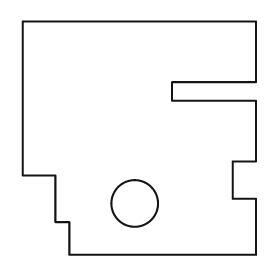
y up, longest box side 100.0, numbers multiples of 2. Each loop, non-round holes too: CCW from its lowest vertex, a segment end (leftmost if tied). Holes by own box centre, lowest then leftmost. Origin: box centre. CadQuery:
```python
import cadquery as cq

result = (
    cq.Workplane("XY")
    .moveTo(-30.0, -50.0)
    .lineTo(50.0, -50.0)
    .lineTo(50.0, -26.0)
    .lineTo(40.0, -26.0)
    .lineTo(40.0, -10.0)
    .lineTo(50.0, -10.0)
    .lineTo(50.0, 16.0)
    .lineTo(14.0, 16.0)
    .lineTo(14.0, 24.0)
    .lineTo(50.0, 24.0)
    .lineTo(50.0, 50.0)
    .lineTo(-50.0, 50.0)
    .lineTo(-50.0, -16.0)
    .lineTo(-36.0, -16.0)
    .lineTo(-36.0, -36.0)
    .lineTo(-30.0, -36.0)
    .close()
    .moveTo(-2.0, -28.0)
    .circle(10.0)
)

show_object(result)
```